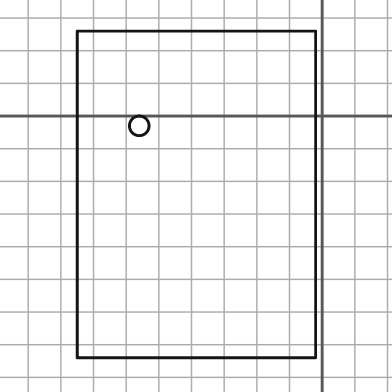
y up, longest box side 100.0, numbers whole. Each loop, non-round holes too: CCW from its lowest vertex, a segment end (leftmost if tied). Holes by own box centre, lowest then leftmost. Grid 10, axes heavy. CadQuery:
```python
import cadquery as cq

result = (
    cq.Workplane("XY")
    .moveTo(-75.0, -74.0)
    .lineTo(-2.0, -74.0)
    .lineTo(-2.0, 26.0)
    .lineTo(-75.0, 26.0)
    .close()
    .moveTo(-56.0, -3.0)
    .circle(3.0)
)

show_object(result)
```